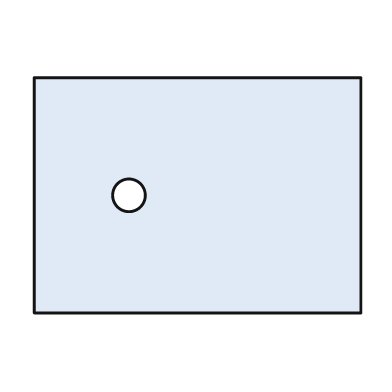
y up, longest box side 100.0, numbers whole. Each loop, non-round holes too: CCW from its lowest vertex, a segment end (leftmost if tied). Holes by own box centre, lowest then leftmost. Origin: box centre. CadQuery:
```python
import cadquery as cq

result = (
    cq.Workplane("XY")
    .moveTo(-50.0, -36.0)
    .lineTo(50.0, -36.0)
    .lineTo(50.0, 36.0)
    .lineTo(-50.0, 36.0)
    .close()
    .moveTo(-21.0, 0.0)
    .circle(5.0)
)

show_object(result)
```